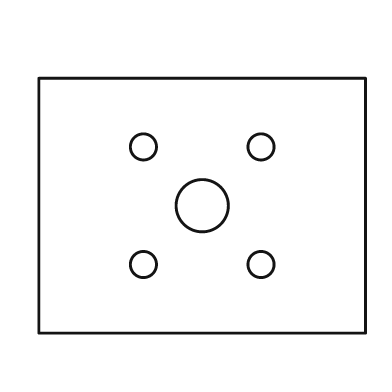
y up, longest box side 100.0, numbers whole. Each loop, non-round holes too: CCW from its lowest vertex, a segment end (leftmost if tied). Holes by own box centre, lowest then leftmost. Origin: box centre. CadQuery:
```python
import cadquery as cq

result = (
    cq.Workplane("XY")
    .moveTo(-50.0, -39.0)
    .lineTo(50.0, -39.0)
    .lineTo(50.0, 39.0)
    .lineTo(-50.0, 39.0)
    .close()
    .moveTo(-18.0, -18.0)
    .circle(4.0)
    .moveTo(18.0, -18.0)
    .circle(4.0)
    .moveTo(0.0, 0.0)
    .circle(8.0)
    .moveTo(-18.0, 18.0)
    .circle(4.0)
    .moveTo(18.0, 18.0)
    .circle(4.0)
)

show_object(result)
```